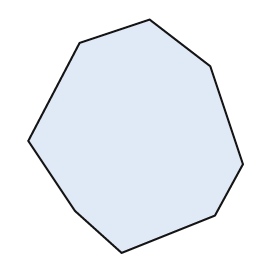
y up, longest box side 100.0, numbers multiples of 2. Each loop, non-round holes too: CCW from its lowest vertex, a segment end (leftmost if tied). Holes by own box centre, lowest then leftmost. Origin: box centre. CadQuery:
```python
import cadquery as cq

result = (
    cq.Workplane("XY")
    .moveTo(-6.0, -50.0)
    .lineTo(34.0, -34.0)
    .lineTo(46.0, -12.0)
    .lineTo(32.0, 30.0)
    .lineTo(6.0, 50.0)
    .lineTo(-24.0, 40.0)
    .lineTo(-46.0, -2.0)
    .lineTo(-26.0, -32.0)
    .close()
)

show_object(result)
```